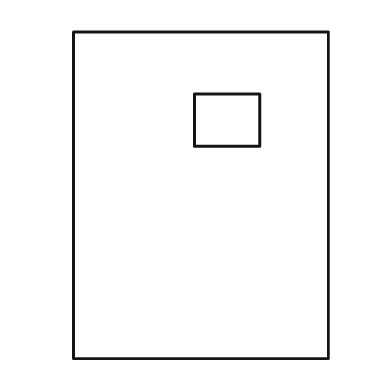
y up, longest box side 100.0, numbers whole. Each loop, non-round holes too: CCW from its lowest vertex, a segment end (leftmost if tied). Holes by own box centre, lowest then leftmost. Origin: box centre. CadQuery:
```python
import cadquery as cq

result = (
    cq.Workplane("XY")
    .moveTo(-39.0, -50.0)
    .lineTo(39.0, -50.0)
    .lineTo(39.0, 50.0)
    .lineTo(-39.0, 50.0)
    .close()
    .moveTo(-2.0, 15.0)
    .lineTo(18.0, 15.0)
    .lineTo(18.0, 31.0)
    .lineTo(-2.0, 31.0)
    .close()
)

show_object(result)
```